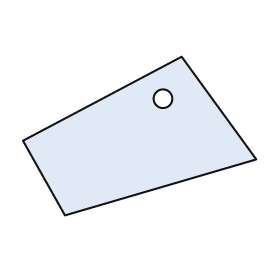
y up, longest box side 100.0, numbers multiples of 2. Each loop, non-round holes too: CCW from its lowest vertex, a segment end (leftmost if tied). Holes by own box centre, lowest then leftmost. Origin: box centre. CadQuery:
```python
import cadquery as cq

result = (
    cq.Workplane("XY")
    .moveTo(-32.0, -34.0)
    .lineTo(50.0, -10.0)
    .lineTo(18.0, 34.0)
    .lineTo(-50.0, -2.0)
    .close()
    .moveTo(10.0, 16.0)
    .circle(4.0)
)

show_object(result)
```